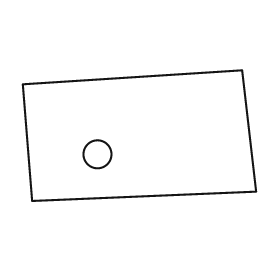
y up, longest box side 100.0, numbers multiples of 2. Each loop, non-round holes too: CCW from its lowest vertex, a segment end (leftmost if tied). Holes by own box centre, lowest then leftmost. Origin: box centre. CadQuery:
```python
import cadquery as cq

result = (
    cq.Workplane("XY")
    .moveTo(-46.0, -28.0)
    .lineTo(50.0, -24.0)
    .lineTo(44.0, 28.0)
    .lineTo(-50.0, 22.0)
    .close()
    .moveTo(-18.0, -8.0)
    .circle(6.0)
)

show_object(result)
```